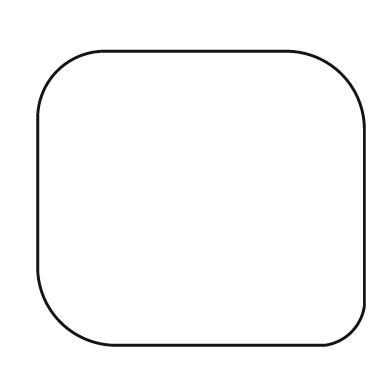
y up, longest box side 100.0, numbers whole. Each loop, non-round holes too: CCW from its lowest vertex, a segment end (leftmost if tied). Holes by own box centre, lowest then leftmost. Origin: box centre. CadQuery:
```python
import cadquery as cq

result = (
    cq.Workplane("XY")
    .moveTo(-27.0, -45.0)
    .lineTo(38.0, -45.0)
    .threePointArc((46.0, -41.0), (50.0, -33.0))
    .lineTo(50.0, 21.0)
    .threePointArc((43.0, 38.0), (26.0, 45.0))
    .lineTo(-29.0, 45.0)
    .threePointArc((-44.0, 39.0), (-50.0, 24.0))
    .lineTo(-50.0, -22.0)
    .threePointArc((-43.0, -38.0), (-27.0, -45.0))
    .close()
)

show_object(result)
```